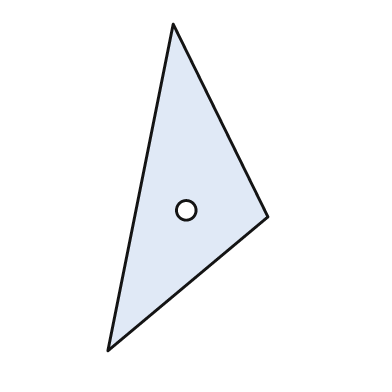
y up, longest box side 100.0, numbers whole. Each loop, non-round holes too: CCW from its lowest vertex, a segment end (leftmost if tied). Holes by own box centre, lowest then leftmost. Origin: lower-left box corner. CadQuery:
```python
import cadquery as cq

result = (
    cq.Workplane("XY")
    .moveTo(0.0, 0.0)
    .lineTo(49.0, 41.0)
    .lineTo(20.0, 100.0)
    .close()
    .moveTo(24.0, 43.0)
    .circle(3.0)
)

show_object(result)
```